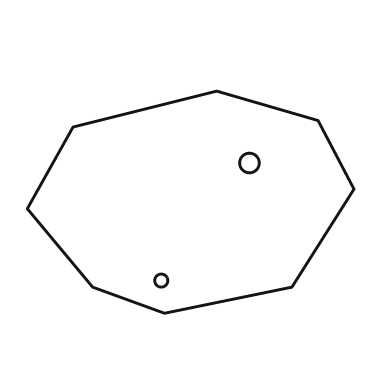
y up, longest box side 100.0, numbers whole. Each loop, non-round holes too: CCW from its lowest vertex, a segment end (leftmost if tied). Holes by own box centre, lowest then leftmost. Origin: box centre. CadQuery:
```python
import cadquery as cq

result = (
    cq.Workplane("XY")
    .moveTo(-8.0, -34.0)
    .lineTo(31.0, -26.0)
    .lineTo(50.0, 4.0)
    .lineTo(39.0, 25.0)
    .lineTo(8.0, 34.0)
    .lineTo(-36.0, 23.0)
    .lineTo(-50.0, -2.0)
    .lineTo(-30.0, -26.0)
    .close()
    .moveTo(-9.0, -24.0)
    .circle(2.0)
    .moveTo(18.0, 12.0)
    .circle(3.0)
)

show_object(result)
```